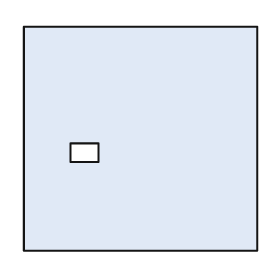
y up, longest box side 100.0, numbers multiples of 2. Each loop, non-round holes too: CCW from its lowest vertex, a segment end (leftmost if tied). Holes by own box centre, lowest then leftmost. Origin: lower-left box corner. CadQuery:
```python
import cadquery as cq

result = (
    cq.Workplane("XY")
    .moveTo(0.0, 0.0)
    .lineTo(100.0, 0.0)
    .lineTo(100.0, 96.0)
    .lineTo(0.0, 96.0)
    .close()
    .moveTo(20.0, 38.0)
    .lineTo(32.0, 38.0)
    .lineTo(32.0, 46.0)
    .lineTo(20.0, 46.0)
    .close()
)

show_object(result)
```